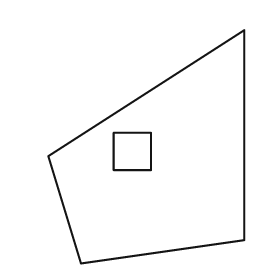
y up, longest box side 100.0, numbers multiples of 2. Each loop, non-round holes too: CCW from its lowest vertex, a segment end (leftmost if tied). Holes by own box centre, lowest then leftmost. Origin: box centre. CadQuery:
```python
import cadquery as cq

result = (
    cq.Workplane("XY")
    .moveTo(-28.0, -50.0)
    .lineTo(42.0, -40.0)
    .lineTo(42.0, 50.0)
    .lineTo(-42.0, -4.0)
    .close()
    .moveTo(-14.0, -10.0)
    .lineTo(2.0, -10.0)
    .lineTo(2.0, 6.0)
    .lineTo(-14.0, 6.0)
    .close()
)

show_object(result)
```